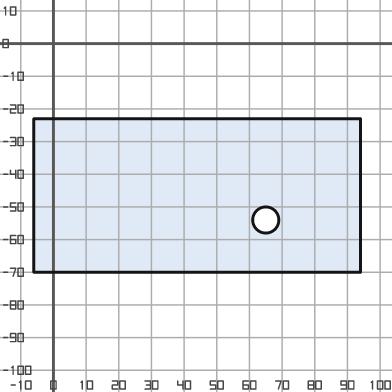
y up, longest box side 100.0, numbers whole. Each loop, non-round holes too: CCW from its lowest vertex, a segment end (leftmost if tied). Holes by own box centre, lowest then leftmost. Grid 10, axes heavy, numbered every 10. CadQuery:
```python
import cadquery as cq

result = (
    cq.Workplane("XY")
    .moveTo(-6.0, -70.0)
    .lineTo(94.0, -70.0)
    .lineTo(94.0, -23.0)
    .lineTo(-6.0, -23.0)
    .close()
    .moveTo(65.0, -54.0)
    .circle(4.0)
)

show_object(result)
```